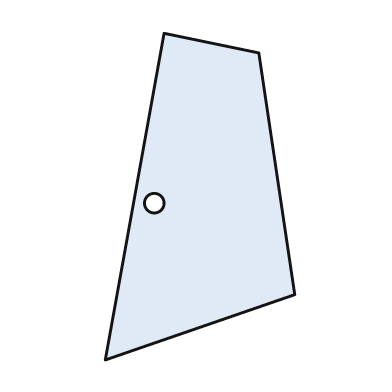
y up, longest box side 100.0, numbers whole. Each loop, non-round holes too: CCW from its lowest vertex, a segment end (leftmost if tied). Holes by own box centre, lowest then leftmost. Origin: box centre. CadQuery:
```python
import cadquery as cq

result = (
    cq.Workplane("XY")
    .moveTo(-29.0, -50.0)
    .lineTo(29.0, -30.0)
    .lineTo(18.0, 44.0)
    .lineTo(-11.0, 50.0)
    .close()
    .moveTo(-14.0, -2.0)
    .circle(3.0)
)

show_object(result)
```